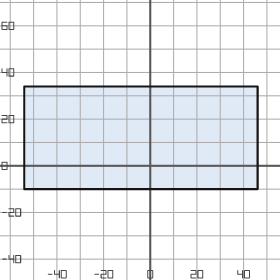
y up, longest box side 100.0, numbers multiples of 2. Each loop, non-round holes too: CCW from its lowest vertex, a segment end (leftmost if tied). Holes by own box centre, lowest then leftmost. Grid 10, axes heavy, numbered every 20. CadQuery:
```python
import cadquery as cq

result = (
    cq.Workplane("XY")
    .moveTo(-54.0, -10.0)
    .lineTo(46.0, -10.0)
    .lineTo(46.0, 34.0)
    .lineTo(-54.0, 34.0)
    .close()
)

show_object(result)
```